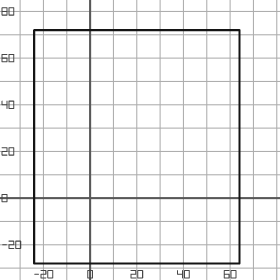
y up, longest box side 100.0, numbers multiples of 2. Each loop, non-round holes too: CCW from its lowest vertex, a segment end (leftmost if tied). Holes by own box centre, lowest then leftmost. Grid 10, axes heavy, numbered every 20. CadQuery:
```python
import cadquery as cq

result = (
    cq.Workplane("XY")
    .moveTo(-24.0, -28.0)
    .lineTo(64.0, -28.0)
    .lineTo(64.0, 72.0)
    .lineTo(-24.0, 72.0)
    .close()
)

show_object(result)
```